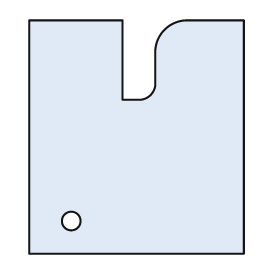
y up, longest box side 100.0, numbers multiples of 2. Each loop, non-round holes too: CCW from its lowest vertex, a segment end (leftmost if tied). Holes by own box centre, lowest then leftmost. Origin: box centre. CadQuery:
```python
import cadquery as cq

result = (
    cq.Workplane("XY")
    .moveTo(-46.0, -50.0)
    .lineTo(46.0, -50.0)
    .lineTo(46.0, 50.0)
    .lineTo(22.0, 50.0)
    .threePointArc((12.0, 46.0), (8.0, 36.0))
    .lineTo(8.0, 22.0)
    .threePointArc((6.0, 18.0), (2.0, 16.0))
    .lineTo(-6.0, 16.0)
    .lineTo(-6.0, 50.0)
    .lineTo(-46.0, 50.0)
    .close()
    .moveTo(-28.0, -36.0)
    .circle(4.0)
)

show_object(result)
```